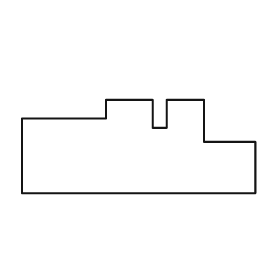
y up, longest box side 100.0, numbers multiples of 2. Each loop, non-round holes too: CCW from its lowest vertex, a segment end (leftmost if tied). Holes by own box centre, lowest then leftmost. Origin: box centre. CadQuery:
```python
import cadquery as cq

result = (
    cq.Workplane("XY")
    .moveTo(-50.0, -20.0)
    .lineTo(50.0, -20.0)
    .lineTo(50.0, 2.0)
    .lineTo(28.0, 2.0)
    .lineTo(28.0, 20.0)
    .lineTo(12.0, 20.0)
    .lineTo(12.0, 8.0)
    .lineTo(6.0, 8.0)
    .lineTo(6.0, 20.0)
    .lineTo(-14.0, 20.0)
    .lineTo(-14.0, 12.0)
    .lineTo(-50.0, 12.0)
    .close()
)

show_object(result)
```